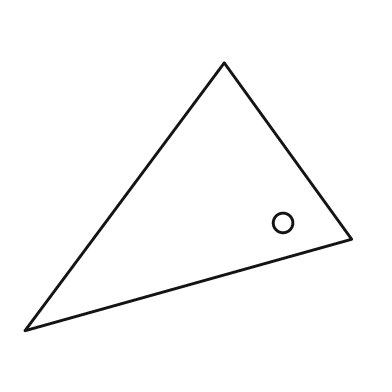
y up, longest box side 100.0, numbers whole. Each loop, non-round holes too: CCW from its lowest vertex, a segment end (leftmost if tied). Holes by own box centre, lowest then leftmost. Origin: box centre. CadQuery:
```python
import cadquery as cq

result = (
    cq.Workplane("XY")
    .moveTo(-50.0, -41.0)
    .lineTo(50.0, -13.0)
    .lineTo(11.0, 41.0)
    .close()
    .moveTo(29.0, -8.0)
    .circle(3.0)
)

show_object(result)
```